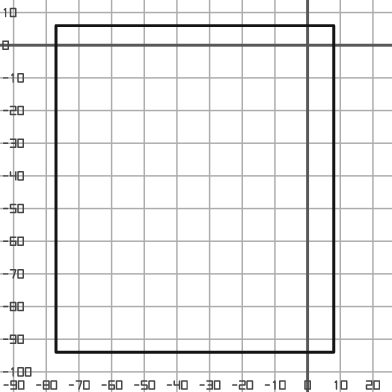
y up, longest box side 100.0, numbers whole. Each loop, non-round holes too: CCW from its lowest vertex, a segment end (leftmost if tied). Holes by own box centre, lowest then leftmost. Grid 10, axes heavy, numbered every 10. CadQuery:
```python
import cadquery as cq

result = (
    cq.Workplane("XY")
    .moveTo(-77.0, -94.0)
    .lineTo(8.0, -94.0)
    .lineTo(8.0, 6.0)
    .lineTo(-77.0, 6.0)
    .close()
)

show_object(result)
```